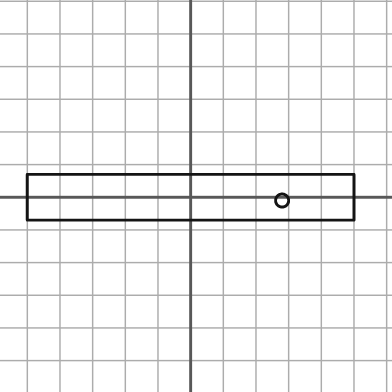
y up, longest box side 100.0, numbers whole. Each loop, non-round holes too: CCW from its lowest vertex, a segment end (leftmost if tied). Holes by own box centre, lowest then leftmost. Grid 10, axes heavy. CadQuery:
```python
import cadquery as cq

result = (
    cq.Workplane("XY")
    .moveTo(-50.0, -7.0)
    .lineTo(50.0, -7.0)
    .lineTo(50.0, 7.0)
    .lineTo(-50.0, 7.0)
    .close()
    .moveTo(28.0, -1.0)
    .circle(2.0)
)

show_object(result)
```